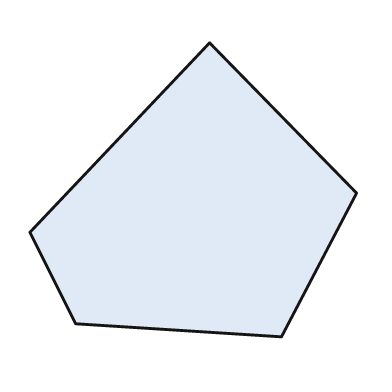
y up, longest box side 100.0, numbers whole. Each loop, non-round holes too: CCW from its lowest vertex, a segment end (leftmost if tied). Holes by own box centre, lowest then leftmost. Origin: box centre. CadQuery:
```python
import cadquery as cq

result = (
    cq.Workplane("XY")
    .moveTo(27.0, -45.0)
    .lineTo(50.0, -1.0)
    .lineTo(5.0, 45.0)
    .lineTo(-50.0, -13.0)
    .lineTo(-36.0, -41.0)
    .close()
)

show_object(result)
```